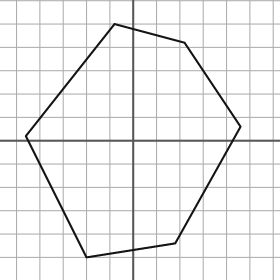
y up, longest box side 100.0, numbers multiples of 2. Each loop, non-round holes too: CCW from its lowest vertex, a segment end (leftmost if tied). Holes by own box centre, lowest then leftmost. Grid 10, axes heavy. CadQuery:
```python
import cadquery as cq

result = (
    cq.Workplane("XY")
    .moveTo(-20.0, -50.0)
    .lineTo(18.0, -44.0)
    .lineTo(46.0, 6.0)
    .lineTo(22.0, 42.0)
    .lineTo(-8.0, 50.0)
    .lineTo(-46.0, 2.0)
    .close()
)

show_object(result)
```